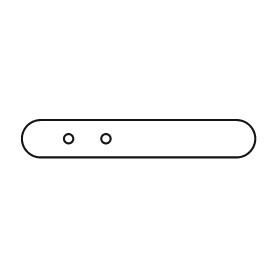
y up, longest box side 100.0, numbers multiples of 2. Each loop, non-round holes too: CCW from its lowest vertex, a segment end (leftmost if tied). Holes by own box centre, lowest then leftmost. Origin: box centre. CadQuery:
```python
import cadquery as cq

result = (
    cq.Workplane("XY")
    .moveTo(-42.0, -8.0)
    .lineTo(42.0, -8.0)
    .threePointArc((50.0, 0.0), (42.0, 8.0))
    .lineTo(-42.0, 8.0)
    .threePointArc((-50.0, 0.0), (-42.0, -8.0))
    .close()
    .moveTo(-30.0, 0.0)
    .circle(2.0)
    .moveTo(-14.0, 0.0)
    .circle(2.0)
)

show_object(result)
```